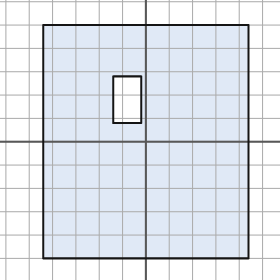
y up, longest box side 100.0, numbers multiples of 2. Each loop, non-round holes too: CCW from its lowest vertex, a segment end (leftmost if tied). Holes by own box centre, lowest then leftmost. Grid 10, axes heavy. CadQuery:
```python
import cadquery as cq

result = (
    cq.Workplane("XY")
    .moveTo(-44.0, -50.0)
    .lineTo(44.0, -50.0)
    .lineTo(44.0, 50.0)
    .lineTo(-44.0, 50.0)
    .close()
    .moveTo(-14.0, 8.0)
    .lineTo(-2.0, 8.0)
    .lineTo(-2.0, 28.0)
    .lineTo(-14.0, 28.0)
    .close()
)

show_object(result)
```